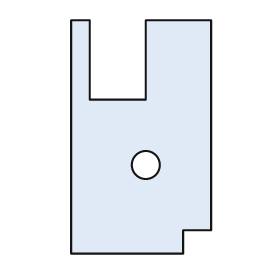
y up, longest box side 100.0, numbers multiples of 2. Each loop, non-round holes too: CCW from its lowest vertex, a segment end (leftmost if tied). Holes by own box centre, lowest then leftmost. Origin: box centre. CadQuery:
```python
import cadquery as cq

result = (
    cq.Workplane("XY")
    .moveTo(-30.0, -50.0)
    .lineTo(18.0, -50.0)
    .lineTo(18.0, -40.0)
    .lineTo(30.0, -40.0)
    .lineTo(30.0, 50.0)
    .lineTo(2.0, 50.0)
    .lineTo(2.0, 16.0)
    .lineTo(-22.0, 16.0)
    .lineTo(-22.0, 50.0)
    .lineTo(-30.0, 50.0)
    .close()
    .moveTo(2.0, -12.0)
    .circle(6.0)
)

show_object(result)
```